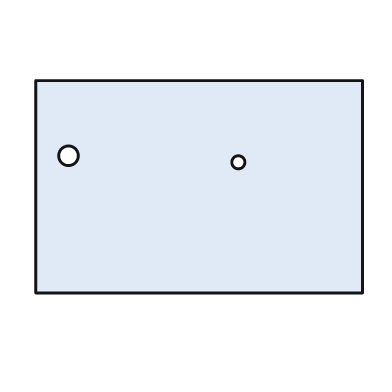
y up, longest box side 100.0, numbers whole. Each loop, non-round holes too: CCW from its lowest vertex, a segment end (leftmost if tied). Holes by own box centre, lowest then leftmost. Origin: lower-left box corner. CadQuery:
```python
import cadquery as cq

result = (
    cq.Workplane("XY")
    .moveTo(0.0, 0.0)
    .lineTo(100.0, 0.0)
    .lineTo(100.0, 65.0)
    .lineTo(0.0, 65.0)
    .close()
    .moveTo(62.0, 40.0)
    .circle(2.0)
    .moveTo(10.0, 42.0)
    .circle(3.0)
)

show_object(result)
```